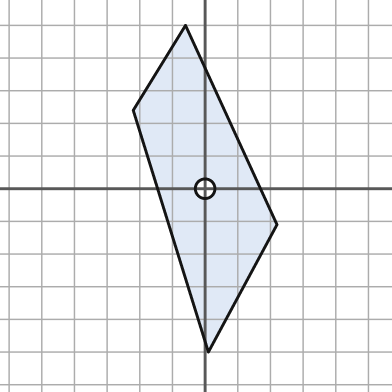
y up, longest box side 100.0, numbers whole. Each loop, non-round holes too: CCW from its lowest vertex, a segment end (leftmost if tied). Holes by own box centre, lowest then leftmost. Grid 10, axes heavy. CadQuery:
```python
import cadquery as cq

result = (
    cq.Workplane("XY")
    .moveTo(1.0, -50.0)
    .lineTo(22.0, -11.0)
    .lineTo(-6.0, 50.0)
    .lineTo(-22.0, 24.0)
    .close()
    .moveTo(0.0, 0.0)
    .circle(3.0)
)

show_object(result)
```